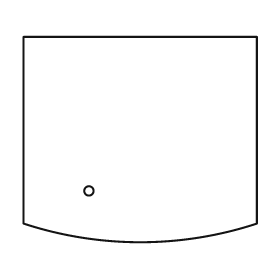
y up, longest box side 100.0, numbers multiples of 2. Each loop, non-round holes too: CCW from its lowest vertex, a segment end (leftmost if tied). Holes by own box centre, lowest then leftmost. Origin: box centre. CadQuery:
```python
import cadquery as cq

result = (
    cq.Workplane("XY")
    .moveTo(-50.0, -36.0)
    .threePointArc((0.0, -44.0), (50.0, -36.0))
    .lineTo(50.0, 44.0)
    .lineTo(-50.0, 44.0)
    .close()
    .moveTo(-22.0, -22.0)
    .circle(2.0)
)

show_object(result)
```